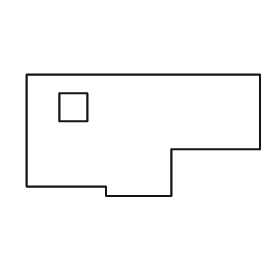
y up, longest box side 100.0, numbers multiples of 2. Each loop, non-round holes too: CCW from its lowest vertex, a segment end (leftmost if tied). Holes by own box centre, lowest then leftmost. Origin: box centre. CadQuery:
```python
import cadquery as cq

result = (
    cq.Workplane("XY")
    .moveTo(-16.0, -26.0)
    .lineTo(12.0, -26.0)
    .lineTo(12.0, -6.0)
    .lineTo(50.0, -6.0)
    .lineTo(50.0, 26.0)
    .lineTo(-50.0, 26.0)
    .lineTo(-50.0, -22.0)
    .lineTo(-16.0, -22.0)
    .close()
    .moveTo(-36.0, 6.0)
    .lineTo(-24.0, 6.0)
    .lineTo(-24.0, 18.0)
    .lineTo(-36.0, 18.0)
    .close()
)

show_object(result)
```